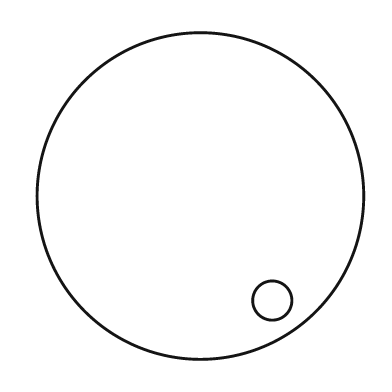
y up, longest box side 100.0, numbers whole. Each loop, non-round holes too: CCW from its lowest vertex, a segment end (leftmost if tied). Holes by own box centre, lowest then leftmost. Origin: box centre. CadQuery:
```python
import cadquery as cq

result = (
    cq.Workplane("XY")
    .moveTo(0.0, 0.0)
    .circle(50.0)
    .moveTo(22.0, -32.0)
    .circle(6.0)
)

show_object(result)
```